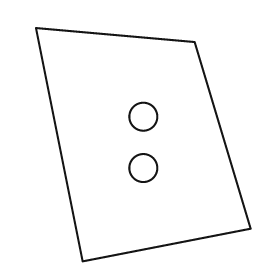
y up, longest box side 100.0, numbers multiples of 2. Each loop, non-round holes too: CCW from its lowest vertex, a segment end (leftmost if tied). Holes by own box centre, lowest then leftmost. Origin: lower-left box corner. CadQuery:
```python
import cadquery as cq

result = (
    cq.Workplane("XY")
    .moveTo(20.0, 0.0)
    .lineTo(92.0, 14.0)
    .lineTo(68.0, 94.0)
    .lineTo(0.0, 100.0)
    .close()
    .moveTo(46.0, 40.0)
    .circle(6.0)
    .moveTo(46.0, 62.0)
    .circle(6.0)
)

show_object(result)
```